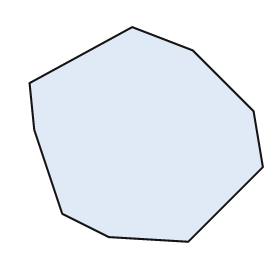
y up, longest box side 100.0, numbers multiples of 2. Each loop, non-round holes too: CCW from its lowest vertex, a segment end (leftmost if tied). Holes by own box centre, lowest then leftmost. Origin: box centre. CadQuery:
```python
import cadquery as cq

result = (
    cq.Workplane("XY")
    .moveTo(18.0, -46.0)
    .lineTo(50.0, -14.0)
    .lineTo(46.0, 10.0)
    .lineTo(20.0, 36.0)
    .lineTo(-6.0, 46.0)
    .lineTo(-50.0, 22.0)
    .lineTo(-48.0, 2.0)
    .lineTo(-36.0, -34.0)
    .lineTo(-16.0, -44.0)
    .close()
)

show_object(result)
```